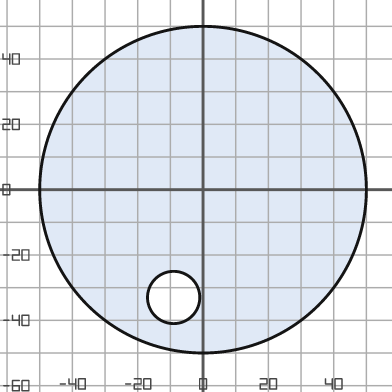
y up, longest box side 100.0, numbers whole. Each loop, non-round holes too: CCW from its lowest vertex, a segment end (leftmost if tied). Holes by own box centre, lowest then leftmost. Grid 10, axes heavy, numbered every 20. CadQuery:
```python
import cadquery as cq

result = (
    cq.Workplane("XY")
    .moveTo(0.0, 0.0)
    .circle(50.0)
    .moveTo(-9.0, -33.0)
    .circle(8.0)
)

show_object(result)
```